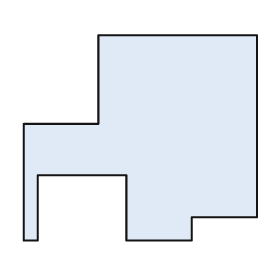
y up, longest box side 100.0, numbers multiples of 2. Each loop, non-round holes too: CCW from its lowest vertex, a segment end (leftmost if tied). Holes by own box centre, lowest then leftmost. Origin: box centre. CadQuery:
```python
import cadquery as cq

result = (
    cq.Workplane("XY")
    .moveTo(-50.0, -44.0)
    .lineTo(-44.0, -44.0)
    .lineTo(-44.0, -16.0)
    .lineTo(-6.0, -16.0)
    .lineTo(-6.0, -44.0)
    .lineTo(22.0, -44.0)
    .lineTo(22.0, -34.0)
    .lineTo(50.0, -34.0)
    .lineTo(50.0, 44.0)
    .lineTo(-18.0, 44.0)
    .lineTo(-18.0, 6.0)
    .lineTo(-50.0, 6.0)
    .close()
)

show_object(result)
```